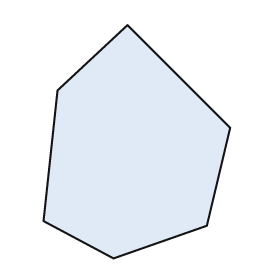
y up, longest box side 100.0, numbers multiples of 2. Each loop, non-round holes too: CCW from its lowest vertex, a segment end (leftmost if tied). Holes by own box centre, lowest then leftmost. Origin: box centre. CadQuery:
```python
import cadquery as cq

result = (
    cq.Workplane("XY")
    .moveTo(-10.0, -50.0)
    .lineTo(30.0, -36.0)
    .lineTo(40.0, 6.0)
    .lineTo(-4.0, 50.0)
    .lineTo(-34.0, 22.0)
    .lineTo(-40.0, -34.0)
    .close()
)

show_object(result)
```